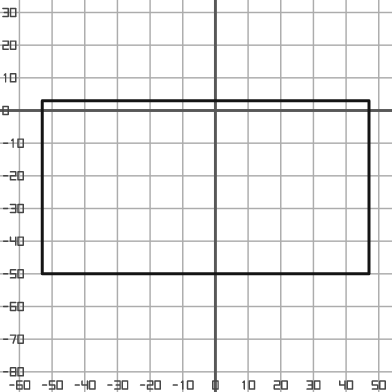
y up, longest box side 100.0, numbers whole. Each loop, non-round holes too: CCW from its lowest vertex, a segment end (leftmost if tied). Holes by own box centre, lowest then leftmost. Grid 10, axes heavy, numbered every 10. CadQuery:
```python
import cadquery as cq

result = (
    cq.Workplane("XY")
    .moveTo(-53.0, -50.0)
    .lineTo(47.0, -50.0)
    .lineTo(47.0, 3.0)
    .lineTo(-53.0, 3.0)
    .close()
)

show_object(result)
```